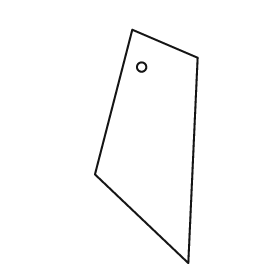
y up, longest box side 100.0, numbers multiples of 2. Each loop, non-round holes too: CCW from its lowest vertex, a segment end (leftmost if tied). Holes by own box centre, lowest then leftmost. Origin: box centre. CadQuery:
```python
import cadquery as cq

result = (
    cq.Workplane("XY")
    .moveTo(18.0, -50.0)
    .lineTo(22.0, 38.0)
    .lineTo(-6.0, 50.0)
    .lineTo(-22.0, -12.0)
    .close()
    .moveTo(-2.0, 34.0)
    .circle(2.0)
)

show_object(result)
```